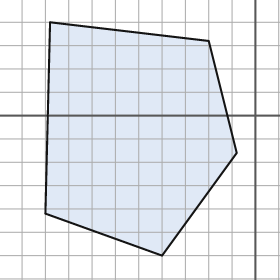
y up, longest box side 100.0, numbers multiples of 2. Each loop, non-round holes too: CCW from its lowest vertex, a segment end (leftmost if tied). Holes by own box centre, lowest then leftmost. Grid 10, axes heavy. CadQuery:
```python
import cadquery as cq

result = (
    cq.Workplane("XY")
    .moveTo(-40.0, -60.0)
    .lineTo(-8.0, -16.0)
    .lineTo(-20.0, 32.0)
    .lineTo(-88.0, 40.0)
    .lineTo(-90.0, -42.0)
    .close()
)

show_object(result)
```